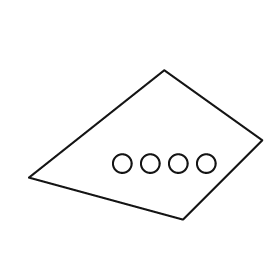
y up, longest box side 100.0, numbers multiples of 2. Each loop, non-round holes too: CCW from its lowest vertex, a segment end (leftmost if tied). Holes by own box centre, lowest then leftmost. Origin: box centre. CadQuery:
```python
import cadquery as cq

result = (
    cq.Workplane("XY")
    .moveTo(16.0, -32.0)
    .lineTo(50.0, 2.0)
    .lineTo(8.0, 32.0)
    .lineTo(-50.0, -14.0)
    .close()
    .moveTo(-10.0, -8.0)
    .circle(4.0)
    .moveTo(2.0, -8.0)
    .circle(4.0)
    .moveTo(14.0, -8.0)
    .circle(4.0)
    .moveTo(26.0, -8.0)
    .circle(4.0)
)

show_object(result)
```